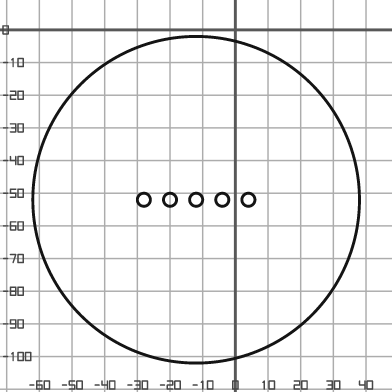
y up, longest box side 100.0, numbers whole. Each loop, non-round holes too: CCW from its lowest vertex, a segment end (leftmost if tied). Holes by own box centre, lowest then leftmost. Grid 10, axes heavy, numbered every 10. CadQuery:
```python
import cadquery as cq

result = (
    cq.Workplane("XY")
    .moveTo(-12.0, -52.0)
    .circle(50.0)
    .moveTo(-28.0, -52.0)
    .circle(2.0)
    .moveTo(-20.0, -52.0)
    .circle(2.0)
    .moveTo(-12.0, -52.0)
    .circle(2.0)
    .moveTo(-4.0, -52.0)
    .circle(2.0)
    .moveTo(4.0, -52.0)
    .circle(2.0)
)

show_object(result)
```